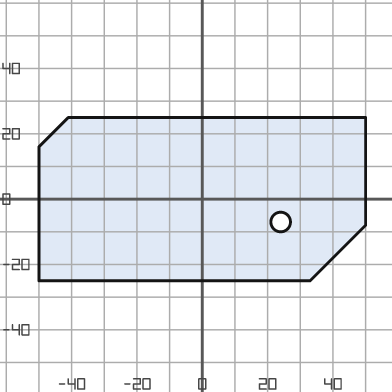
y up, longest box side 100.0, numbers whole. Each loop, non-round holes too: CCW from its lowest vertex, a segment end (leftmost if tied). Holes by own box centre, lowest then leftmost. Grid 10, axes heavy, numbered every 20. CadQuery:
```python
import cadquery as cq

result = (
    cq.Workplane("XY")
    .moveTo(-50.0, -25.0)
    .lineTo(33.0, -25.0)
    .lineTo(50.0, -8.0)
    .lineTo(50.0, 25.0)
    .lineTo(-41.0, 25.0)
    .lineTo(-50.0, 16.0)
    .close()
    .moveTo(24.0, -7.0)
    .circle(3.0)
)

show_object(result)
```